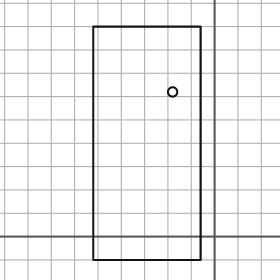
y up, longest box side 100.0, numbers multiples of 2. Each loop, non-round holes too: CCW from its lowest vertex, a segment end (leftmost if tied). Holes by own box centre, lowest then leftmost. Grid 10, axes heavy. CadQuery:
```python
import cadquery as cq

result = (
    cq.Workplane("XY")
    .moveTo(-52.0, -10.0)
    .lineTo(-6.0, -10.0)
    .lineTo(-6.0, 90.0)
    .lineTo(-52.0, 90.0)
    .close()
    .moveTo(-18.0, 62.0)
    .circle(2.0)
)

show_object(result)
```